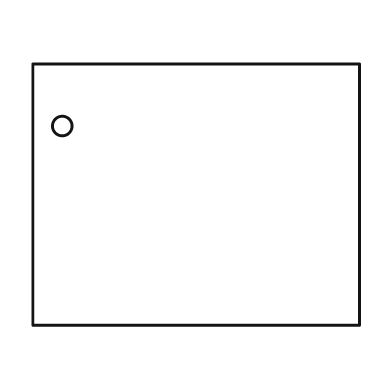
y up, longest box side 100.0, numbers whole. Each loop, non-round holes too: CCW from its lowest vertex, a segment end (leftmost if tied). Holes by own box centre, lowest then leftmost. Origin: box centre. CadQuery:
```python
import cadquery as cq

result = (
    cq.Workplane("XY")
    .moveTo(-50.0, -40.0)
    .lineTo(50.0, -40.0)
    .lineTo(50.0, 40.0)
    .lineTo(-50.0, 40.0)
    .close()
    .moveTo(-41.0, 21.0)
    .circle(3.0)
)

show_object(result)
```